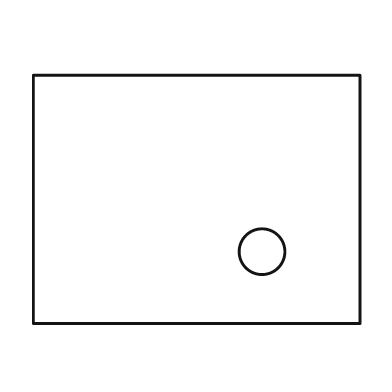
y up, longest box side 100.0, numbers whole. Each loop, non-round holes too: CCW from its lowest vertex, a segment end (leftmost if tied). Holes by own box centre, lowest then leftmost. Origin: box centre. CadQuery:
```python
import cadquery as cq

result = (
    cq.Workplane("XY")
    .moveTo(-50.0, -38.0)
    .lineTo(50.0, -38.0)
    .lineTo(50.0, 38.0)
    .lineTo(-50.0, 38.0)
    .close()
    .moveTo(20.0, -16.0)
    .circle(7.0)
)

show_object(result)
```